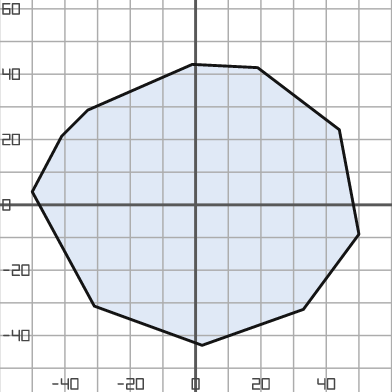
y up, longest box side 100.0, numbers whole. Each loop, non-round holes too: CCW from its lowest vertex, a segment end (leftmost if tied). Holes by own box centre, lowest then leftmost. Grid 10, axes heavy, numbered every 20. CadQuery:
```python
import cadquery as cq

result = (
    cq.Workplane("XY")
    .moveTo(2.0, -43.0)
    .lineTo(33.0, -32.0)
    .lineTo(50.0, -9.0)
    .lineTo(44.0, 23.0)
    .lineTo(19.0, 42.0)
    .lineTo(-1.0, 43.0)
    .lineTo(-33.0, 29.0)
    .lineTo(-41.0, 21.0)
    .lineTo(-50.0, 4.0)
    .lineTo(-31.0, -31.0)
    .close()
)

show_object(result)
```